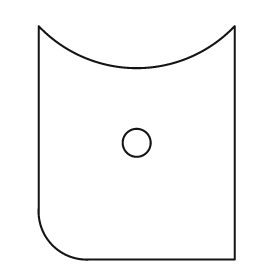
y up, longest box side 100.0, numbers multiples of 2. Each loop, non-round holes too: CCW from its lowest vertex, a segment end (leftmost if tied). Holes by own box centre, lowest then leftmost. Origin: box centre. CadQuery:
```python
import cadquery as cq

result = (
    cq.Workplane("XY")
    .moveTo(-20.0, -50.0)
    .lineTo(42.0, -50.0)
    .lineTo(42.0, 50.0)
    .threePointArc((0.0, 32.0), (-42.0, 50.0))
    .lineTo(-42.0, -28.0)
    .threePointArc((-36.0, -44.0), (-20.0, -50.0))
    .close()
    .moveTo(0.0, 0.0)
    .circle(6.0)
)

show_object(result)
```